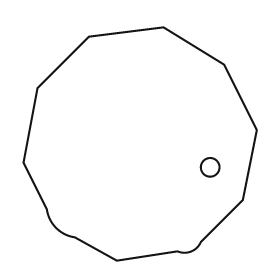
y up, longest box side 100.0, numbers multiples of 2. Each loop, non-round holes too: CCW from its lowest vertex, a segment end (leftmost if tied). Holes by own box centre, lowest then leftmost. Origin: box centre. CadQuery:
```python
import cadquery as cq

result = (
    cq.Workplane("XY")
    .moveTo(-10.0, -50.0)
    .lineTo(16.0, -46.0)
    .threePointArc((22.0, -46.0), (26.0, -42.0))
    .lineTo(44.0, -24.0)
    .lineTo(50.0, 6.0)
    .lineTo(36.0, 34.0)
    .lineTo(10.0, 50.0)
    .lineTo(-22.0, 46.0)
    .lineTo(-44.0, 24.0)
    .lineTo(-50.0, -8.0)
    .lineTo(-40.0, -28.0)
    .threePointArc((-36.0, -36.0), (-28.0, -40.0))
    .close()
    .moveTo(30.0, -10.0)
    .circle(4.0)
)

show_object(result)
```